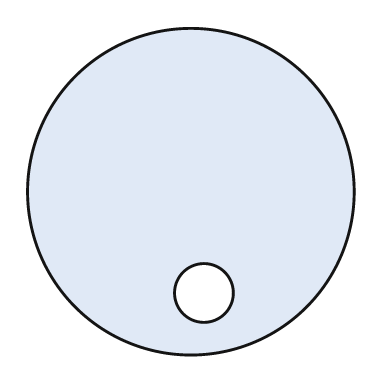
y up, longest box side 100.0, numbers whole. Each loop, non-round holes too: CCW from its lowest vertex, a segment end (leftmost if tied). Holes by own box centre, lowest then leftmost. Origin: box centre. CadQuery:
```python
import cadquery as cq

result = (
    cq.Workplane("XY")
    .moveTo(0.0, 0.0)
    .circle(50.0)
    .moveTo(4.0, -31.0)
    .circle(9.0)
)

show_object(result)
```